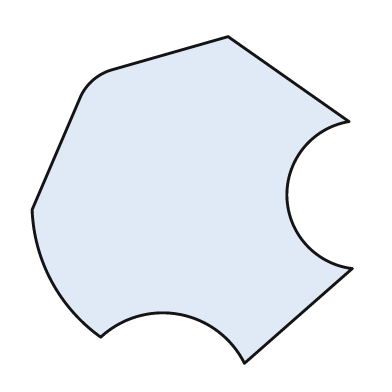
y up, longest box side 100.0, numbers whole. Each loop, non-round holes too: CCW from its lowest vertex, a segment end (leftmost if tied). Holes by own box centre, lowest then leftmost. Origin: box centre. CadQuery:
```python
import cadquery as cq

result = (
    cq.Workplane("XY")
    .moveTo(16.0, -50.0)
    .lineTo(49.0, -21.0)
    .threePointArc((29.0, 1.0), (48.0, 24.0))
    .lineTo(11.0, 50.0)
    .lineTo(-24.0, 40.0)
    .threePointArc((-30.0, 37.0), (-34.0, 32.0))
    .lineTo(-49.0, -3.0)
    .threePointArc((-43.0, -25.0), (-28.0, -42.0))
    .threePointArc((-4.0, -35.0), (16.0, -50.0))
    .close()
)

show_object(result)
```